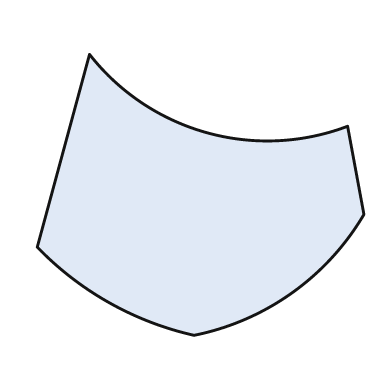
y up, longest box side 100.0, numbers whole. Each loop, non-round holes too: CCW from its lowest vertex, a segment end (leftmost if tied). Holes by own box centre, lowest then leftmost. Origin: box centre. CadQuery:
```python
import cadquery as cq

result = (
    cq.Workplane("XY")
    .moveTo(-2.0, -43.0)
    .threePointArc((28.0, -30.0), (50.0, -6.0))
    .lineTo(45.0, 21.0)
    .threePointArc((2.0, 19.0), (-34.0, 43.0))
    .lineTo(-50.0, -16.0)
    .threePointArc((-28.0, -33.0), (-2.0, -43.0))
    .close()
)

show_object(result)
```